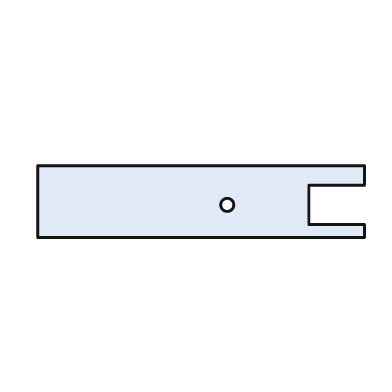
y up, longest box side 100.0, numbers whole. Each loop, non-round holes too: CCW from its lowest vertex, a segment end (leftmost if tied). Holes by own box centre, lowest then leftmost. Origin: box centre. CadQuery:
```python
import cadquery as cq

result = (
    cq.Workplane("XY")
    .moveTo(-50.0, -11.0)
    .lineTo(50.0, -11.0)
    .lineTo(50.0, -7.0)
    .lineTo(33.0, -7.0)
    .lineTo(33.0, 5.0)
    .lineTo(50.0, 5.0)
    .lineTo(50.0, 11.0)
    .lineTo(-50.0, 11.0)
    .close()
    .moveTo(8.0, -1.0)
    .circle(2.0)
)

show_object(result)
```